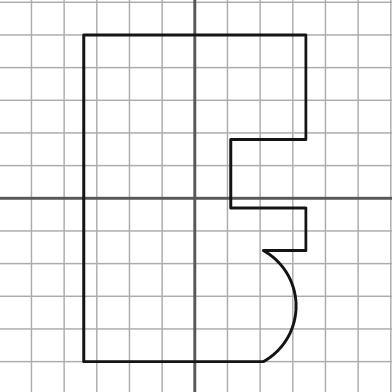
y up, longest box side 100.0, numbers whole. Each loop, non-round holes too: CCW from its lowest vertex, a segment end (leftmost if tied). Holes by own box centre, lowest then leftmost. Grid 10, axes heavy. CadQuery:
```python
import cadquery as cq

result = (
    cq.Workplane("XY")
    .moveTo(-34.0, -50.0)
    .lineTo(21.0, -50.0)
    .threePointArc((31.0, -33.0), (21.0, -16.0))
    .lineTo(34.0, -16.0)
    .lineTo(34.0, -3.0)
    .lineTo(11.0, -3.0)
    .lineTo(11.0, 18.0)
    .lineTo(34.0, 18.0)
    .lineTo(34.0, 50.0)
    .lineTo(-34.0, 50.0)
    .close()
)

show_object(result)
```